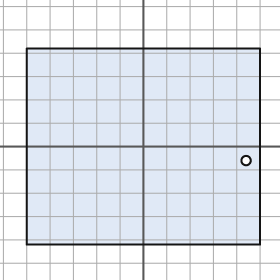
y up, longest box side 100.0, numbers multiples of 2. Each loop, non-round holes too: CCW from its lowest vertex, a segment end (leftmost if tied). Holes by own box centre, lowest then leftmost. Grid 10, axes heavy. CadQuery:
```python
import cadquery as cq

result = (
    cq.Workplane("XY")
    .moveTo(-50.0, -42.0)
    .lineTo(50.0, -42.0)
    .lineTo(50.0, 42.0)
    .lineTo(-50.0, 42.0)
    .close()
    .moveTo(44.0, -6.0)
    .circle(2.0)
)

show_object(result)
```